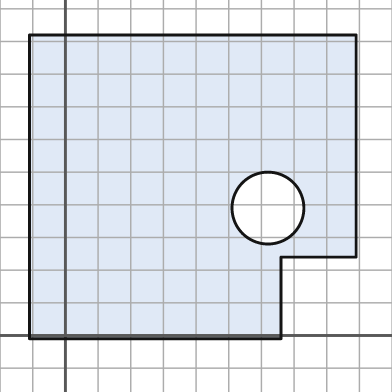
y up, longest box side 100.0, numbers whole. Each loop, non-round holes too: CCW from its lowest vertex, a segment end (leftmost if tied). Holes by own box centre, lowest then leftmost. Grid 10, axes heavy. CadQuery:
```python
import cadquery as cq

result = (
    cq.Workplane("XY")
    .moveTo(-11.0, -1.0)
    .lineTo(66.0, -1.0)
    .lineTo(66.0, 24.0)
    .lineTo(89.0, 24.0)
    .lineTo(89.0, 92.0)
    .lineTo(-11.0, 92.0)
    .close()
    .moveTo(62.0, 39.0)
    .circle(11.0)
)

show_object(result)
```